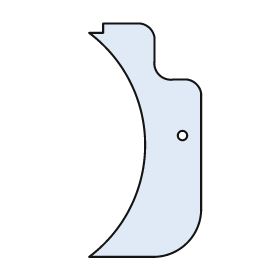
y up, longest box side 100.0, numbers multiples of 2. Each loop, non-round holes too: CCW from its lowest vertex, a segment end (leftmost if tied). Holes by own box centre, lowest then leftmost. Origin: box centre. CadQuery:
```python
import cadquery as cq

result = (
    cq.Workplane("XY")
    .moveTo(-24.0, -50.0)
    .lineTo(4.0, -50.0)
    .threePointArc((18.0, -44.0), (24.0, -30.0))
    .lineTo(24.0, 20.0)
    .threePointArc((22.0, 24.0), (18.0, 26.0))
    .lineTo(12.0, 26.0)
    .threePointArc((6.0, 28.0), (4.0, 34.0))
    .lineTo(4.0, 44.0)
    .threePointArc((2.0, 48.0), (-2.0, 50.0))
    .lineTo(-18.0, 50.0)
    .lineTo(-18.0, 46.0)
    .lineTo(-24.0, 46.0)
    .threePointArc((0.0, -2.0), (-24.0, -50.0))
    .close()
    .moveTo(16.0, 2.0)
    .circle(2.0)
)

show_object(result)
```